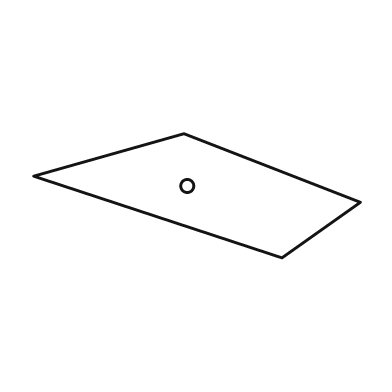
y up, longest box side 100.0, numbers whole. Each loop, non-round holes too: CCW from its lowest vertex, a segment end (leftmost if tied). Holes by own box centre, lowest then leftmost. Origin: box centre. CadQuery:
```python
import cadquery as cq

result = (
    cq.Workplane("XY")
    .moveTo(26.0, -19.0)
    .lineTo(50.0, -2.0)
    .lineTo(-4.0, 19.0)
    .lineTo(-50.0, 6.0)
    .close()
    .moveTo(-3.0, 3.0)
    .circle(2.0)
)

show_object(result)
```